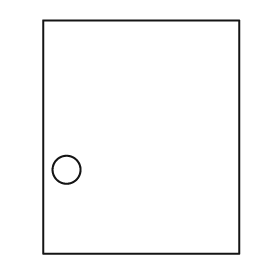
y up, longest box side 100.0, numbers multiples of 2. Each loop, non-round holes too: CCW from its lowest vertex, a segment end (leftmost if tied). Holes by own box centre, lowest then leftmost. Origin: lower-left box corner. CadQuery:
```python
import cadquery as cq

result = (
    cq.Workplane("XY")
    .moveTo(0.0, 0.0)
    .lineTo(84.0, 0.0)
    .lineTo(84.0, 100.0)
    .lineTo(0.0, 100.0)
    .close()
    .moveTo(10.0, 36.0)
    .circle(6.0)
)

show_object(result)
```